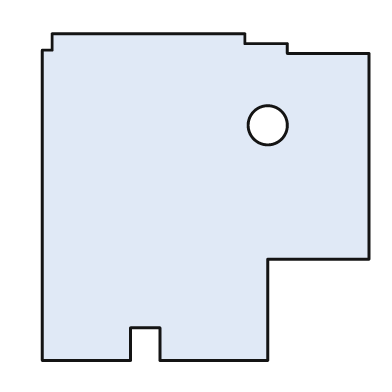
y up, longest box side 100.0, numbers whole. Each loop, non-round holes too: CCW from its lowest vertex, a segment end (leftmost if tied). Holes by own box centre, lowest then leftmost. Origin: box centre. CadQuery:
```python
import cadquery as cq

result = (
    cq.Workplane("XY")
    .moveTo(-50.0, -50.0)
    .lineTo(-23.0, -50.0)
    .lineTo(-23.0, -40.0)
    .lineTo(-14.0, -40.0)
    .lineTo(-14.0, -50.0)
    .lineTo(19.0, -50.0)
    .lineTo(19.0, -19.0)
    .lineTo(50.0, -19.0)
    .lineTo(50.0, 44.0)
    .lineTo(25.0, 44.0)
    .lineTo(25.0, 47.0)
    .lineTo(12.0, 47.0)
    .lineTo(12.0, 50.0)
    .lineTo(-47.0, 50.0)
    .lineTo(-47.0, 45.0)
    .lineTo(-50.0, 45.0)
    .close()
    .moveTo(19.0, 22.0)
    .circle(6.0)
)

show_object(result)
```